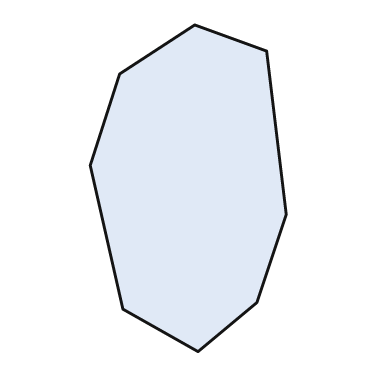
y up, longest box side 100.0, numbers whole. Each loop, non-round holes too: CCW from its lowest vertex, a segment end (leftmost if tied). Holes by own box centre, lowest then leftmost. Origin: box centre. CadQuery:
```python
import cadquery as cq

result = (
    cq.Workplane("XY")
    .moveTo(3.0, -50.0)
    .lineTo(21.0, -35.0)
    .lineTo(30.0, -8.0)
    .lineTo(24.0, 42.0)
    .lineTo(2.0, 50.0)
    .lineTo(-21.0, 35.0)
    .lineTo(-30.0, 7.0)
    .lineTo(-20.0, -37.0)
    .close()
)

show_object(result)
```